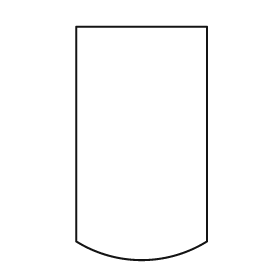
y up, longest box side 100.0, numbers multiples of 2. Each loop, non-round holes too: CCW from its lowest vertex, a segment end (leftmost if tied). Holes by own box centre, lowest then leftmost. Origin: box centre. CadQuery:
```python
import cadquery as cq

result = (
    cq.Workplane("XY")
    .moveTo(-28.0, -42.0)
    .threePointArc((0.0, -50.0), (28.0, -42.0))
    .lineTo(28.0, 50.0)
    .lineTo(-28.0, 50.0)
    .close()
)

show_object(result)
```